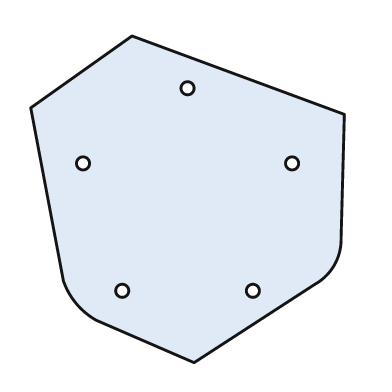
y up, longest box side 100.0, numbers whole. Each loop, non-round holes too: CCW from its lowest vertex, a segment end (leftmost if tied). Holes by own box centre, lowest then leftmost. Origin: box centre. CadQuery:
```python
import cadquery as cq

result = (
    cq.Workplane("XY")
    .moveTo(2.0, -50.0)
    .lineTo(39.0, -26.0)
    .threePointArc((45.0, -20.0), (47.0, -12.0))
    .lineTo(48.0, 26.0)
    .lineTo(-17.0, 50.0)
    .lineTo(-48.0, 28.0)
    .lineTo(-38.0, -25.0)
    .threePointArc((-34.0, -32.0), (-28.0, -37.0))
    .close()
    .moveTo(-20.0, -28.0)
    .circle(2.0)
    .moveTo(20.0, -28.0)
    .circle(2.0)
    .moveTo(-32.0, 11.0)
    .circle(2.0)
    .moveTo(32.0, 11.0)
    .circle(2.0)
    .moveTo(0.0, 34.0)
    .circle(2.0)
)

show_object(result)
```